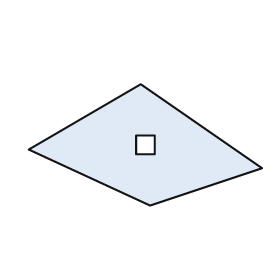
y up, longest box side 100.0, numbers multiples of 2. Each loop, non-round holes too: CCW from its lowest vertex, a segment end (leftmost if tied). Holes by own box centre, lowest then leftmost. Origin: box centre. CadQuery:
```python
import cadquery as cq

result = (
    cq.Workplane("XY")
    .moveTo(2.0, -26.0)
    .lineTo(50.0, -10.0)
    .lineTo(-2.0, 26.0)
    .lineTo(-50.0, -2.0)
    .close()
    .moveTo(-4.0, -4.0)
    .lineTo(4.0, -4.0)
    .lineTo(4.0, 4.0)
    .lineTo(-4.0, 4.0)
    .close()
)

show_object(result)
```